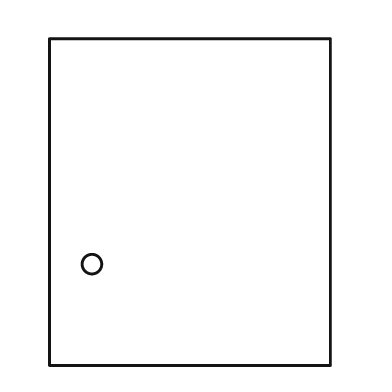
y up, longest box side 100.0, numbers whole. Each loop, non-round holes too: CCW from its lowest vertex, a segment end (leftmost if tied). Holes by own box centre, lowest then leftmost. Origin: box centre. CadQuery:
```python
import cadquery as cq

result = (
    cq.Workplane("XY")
    .moveTo(-43.0, -50.0)
    .lineTo(43.0, -50.0)
    .lineTo(43.0, 50.0)
    .lineTo(-43.0, 50.0)
    .close()
    .moveTo(-30.0, -19.0)
    .circle(3.0)
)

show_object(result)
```